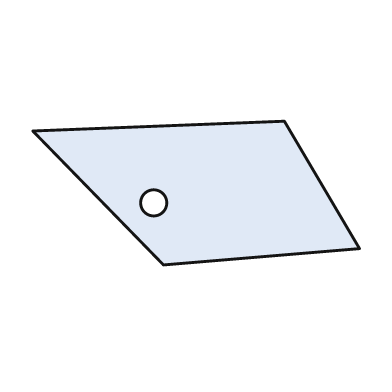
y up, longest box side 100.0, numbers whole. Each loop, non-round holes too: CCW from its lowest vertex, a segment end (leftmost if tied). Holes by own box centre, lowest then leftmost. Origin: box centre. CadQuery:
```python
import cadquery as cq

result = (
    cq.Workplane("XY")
    .moveTo(-10.0, -22.0)
    .lineTo(50.0, -17.0)
    .lineTo(27.0, 22.0)
    .lineTo(-50.0, 19.0)
    .close()
    .moveTo(-13.0, -3.0)
    .circle(4.0)
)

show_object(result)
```